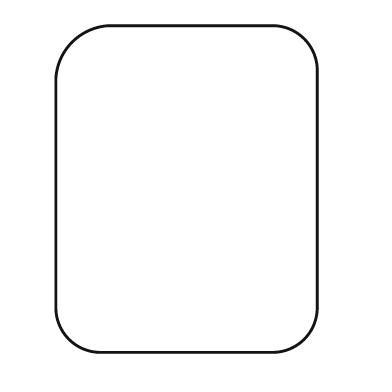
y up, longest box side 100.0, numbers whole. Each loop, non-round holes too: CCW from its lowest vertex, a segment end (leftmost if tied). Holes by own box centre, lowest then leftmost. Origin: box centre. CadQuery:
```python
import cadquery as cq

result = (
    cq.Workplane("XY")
    .moveTo(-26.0, -50.0)
    .lineTo(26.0, -50.0)
    .threePointArc((36.0, -46.0), (40.0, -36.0))
    .lineTo(40.0, 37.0)
    .threePointArc((36.0, 46.0), (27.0, 50.0))
    .lineTo(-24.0, 50.0)
    .threePointArc((-35.0, 45.0), (-40.0, 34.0))
    .lineTo(-40.0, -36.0)
    .threePointArc((-36.0, -46.0), (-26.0, -50.0))
    .close()
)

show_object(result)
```